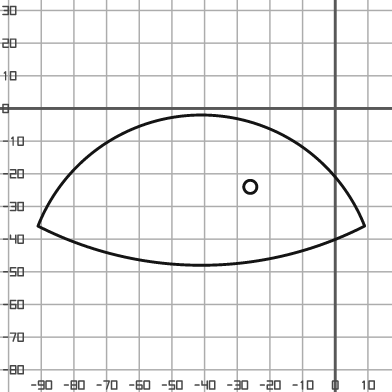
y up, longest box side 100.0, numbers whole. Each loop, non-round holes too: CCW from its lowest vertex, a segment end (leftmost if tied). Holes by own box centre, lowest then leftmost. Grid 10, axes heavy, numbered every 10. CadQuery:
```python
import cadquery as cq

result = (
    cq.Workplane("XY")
    .moveTo(-91.0, -36.0)
    .threePointArc((-41.0, -48.0), (9.0, -36.0))
    .threePointArc((-41.0, -2.0), (-91.0, -36.0))
    .close()
    .moveTo(-26.0, -24.0)
    .circle(2.0)
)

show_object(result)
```